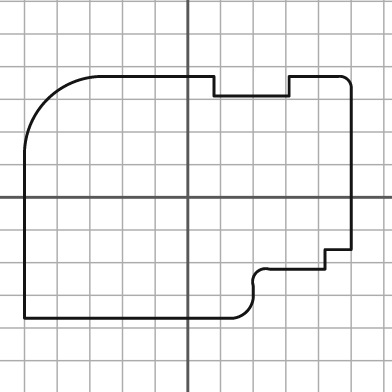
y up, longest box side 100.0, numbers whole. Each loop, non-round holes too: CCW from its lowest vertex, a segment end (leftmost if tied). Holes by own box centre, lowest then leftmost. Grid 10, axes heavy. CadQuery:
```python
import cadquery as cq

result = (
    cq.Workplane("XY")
    .moveTo(-50.0, -37.0)
    .lineTo(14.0, -37.0)
    .threePointArc((18.0, -35.0), (20.0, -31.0))
    .lineTo(20.0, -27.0)
    .threePointArc((21.0, -23.0), (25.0, -22.0))
    .lineTo(42.0, -22.0)
    .lineTo(42.0, -16.0)
    .lineTo(50.0, -16.0)
    .lineTo(50.0, 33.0)
    .threePointArc((49.0, 36.0), (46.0, 37.0))
    .lineTo(31.0, 37.0)
    .lineTo(31.0, 31.0)
    .lineTo(8.0, 31.0)
    .lineTo(8.0, 37.0)
    .lineTo(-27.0, 37.0)
    .threePointArc((-43.0, 30.0), (-50.0, 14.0))
    .close()
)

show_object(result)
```